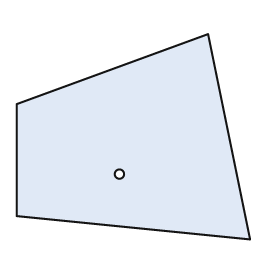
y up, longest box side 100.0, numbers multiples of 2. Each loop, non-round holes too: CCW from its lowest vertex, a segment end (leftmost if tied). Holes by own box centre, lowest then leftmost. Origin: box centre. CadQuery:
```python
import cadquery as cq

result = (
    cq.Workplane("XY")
    .moveTo(50.0, -44.0)
    .lineTo(32.0, 44.0)
    .lineTo(-50.0, 14.0)
    .lineTo(-50.0, -34.0)
    .close()
    .moveTo(-6.0, -16.0)
    .circle(2.0)
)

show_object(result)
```